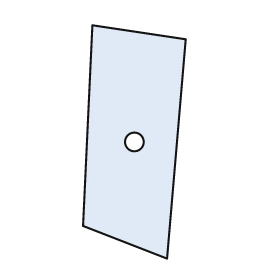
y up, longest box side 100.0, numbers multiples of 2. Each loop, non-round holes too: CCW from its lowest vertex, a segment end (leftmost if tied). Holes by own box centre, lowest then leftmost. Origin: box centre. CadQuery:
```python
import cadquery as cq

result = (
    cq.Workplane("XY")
    .moveTo(14.0, -50.0)
    .lineTo(22.0, 44.0)
    .lineTo(-18.0, 50.0)
    .lineTo(-22.0, -36.0)
    .close()
    .moveTo(0.0, 0.0)
    .circle(4.0)
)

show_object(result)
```